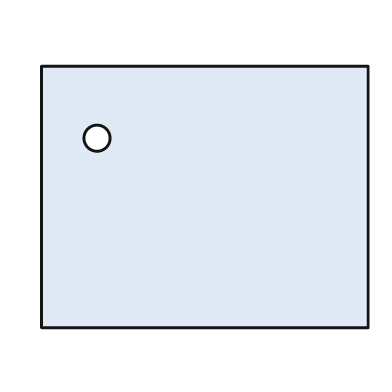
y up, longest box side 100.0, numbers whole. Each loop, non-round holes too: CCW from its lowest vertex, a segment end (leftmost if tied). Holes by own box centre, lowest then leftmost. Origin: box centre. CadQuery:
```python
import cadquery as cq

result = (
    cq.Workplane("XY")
    .moveTo(-50.0, -40.0)
    .lineTo(50.0, -40.0)
    .lineTo(50.0, 40.0)
    .lineTo(-50.0, 40.0)
    .close()
    .moveTo(-33.0, 18.0)
    .circle(4.0)
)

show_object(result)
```